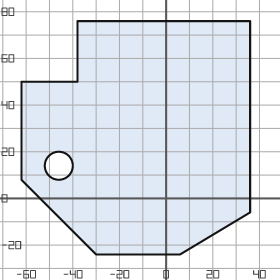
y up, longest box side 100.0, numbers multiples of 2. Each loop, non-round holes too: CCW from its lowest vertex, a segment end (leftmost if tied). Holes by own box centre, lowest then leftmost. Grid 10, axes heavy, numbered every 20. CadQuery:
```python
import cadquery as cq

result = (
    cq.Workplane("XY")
    .moveTo(-30.0, -24.0)
    .lineTo(6.0, -24.0)
    .lineTo(36.0, -6.0)
    .lineTo(36.0, 76.0)
    .lineTo(-38.0, 76.0)
    .lineTo(-38.0, 50.0)
    .lineTo(-62.0, 50.0)
    .lineTo(-62.0, 8.0)
    .close()
    .moveTo(-46.0, 14.0)
    .circle(6.0)
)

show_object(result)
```